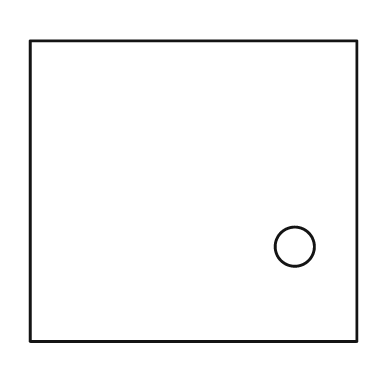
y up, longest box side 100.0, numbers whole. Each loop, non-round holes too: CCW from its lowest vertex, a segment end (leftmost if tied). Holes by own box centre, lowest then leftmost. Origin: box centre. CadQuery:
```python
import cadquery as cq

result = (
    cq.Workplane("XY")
    .moveTo(-50.0, -46.0)
    .lineTo(50.0, -46.0)
    .lineTo(50.0, 46.0)
    .lineTo(-50.0, 46.0)
    .close()
    .moveTo(31.0, -17.0)
    .circle(6.0)
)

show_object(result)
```